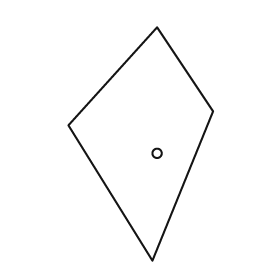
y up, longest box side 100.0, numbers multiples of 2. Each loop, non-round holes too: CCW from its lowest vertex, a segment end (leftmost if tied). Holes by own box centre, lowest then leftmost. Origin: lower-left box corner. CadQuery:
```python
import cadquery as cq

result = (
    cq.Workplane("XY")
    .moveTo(36.0, 0.0)
    .lineTo(62.0, 64.0)
    .lineTo(38.0, 100.0)
    .lineTo(0.0, 58.0)
    .close()
    .moveTo(38.0, 46.0)
    .circle(2.0)
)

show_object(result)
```